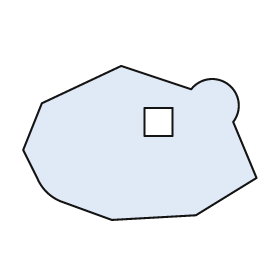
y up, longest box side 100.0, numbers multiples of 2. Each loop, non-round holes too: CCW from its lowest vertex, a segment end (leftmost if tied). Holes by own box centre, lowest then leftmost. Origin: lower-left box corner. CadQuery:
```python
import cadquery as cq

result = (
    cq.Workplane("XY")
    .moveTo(38.0, 0.0)
    .lineTo(74.0, 2.0)
    .lineTo(100.0, 18.0)
    .lineTo(90.0, 42.0)
    .threePointArc((88.0, 58.0), (72.0, 56.0))
    .lineTo(42.0, 66.0)
    .lineTo(8.0, 50.0)
    .lineTo(0.0, 30.0)
    .lineTo(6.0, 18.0)
    .threePointArc((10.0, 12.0), (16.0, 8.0))
    .close()
    .moveTo(52.0, 36.0)
    .lineTo(64.0, 36.0)
    .lineTo(64.0, 48.0)
    .lineTo(52.0, 48.0)
    .close()
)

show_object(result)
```